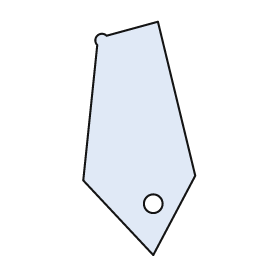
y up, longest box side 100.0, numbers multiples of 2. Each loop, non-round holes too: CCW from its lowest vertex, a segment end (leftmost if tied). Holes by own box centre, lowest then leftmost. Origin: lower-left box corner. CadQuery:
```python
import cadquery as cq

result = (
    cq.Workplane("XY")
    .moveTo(30.0, 0.0)
    .lineTo(48.0, 34.0)
    .lineTo(32.0, 100.0)
    .lineTo(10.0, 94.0)
    .threePointArc((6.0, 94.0), (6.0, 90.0))
    .lineTo(0.0, 32.0)
    .close()
    .moveTo(30.0, 22.0)
    .circle(4.0)
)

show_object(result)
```